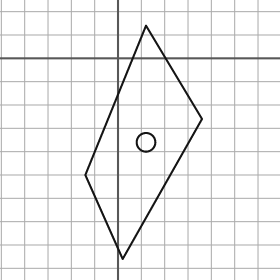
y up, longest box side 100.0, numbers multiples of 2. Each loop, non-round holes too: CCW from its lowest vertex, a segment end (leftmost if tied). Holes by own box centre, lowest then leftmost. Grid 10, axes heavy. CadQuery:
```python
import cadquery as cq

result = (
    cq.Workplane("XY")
    .moveTo(2.0, -86.0)
    .lineTo(36.0, -26.0)
    .lineTo(12.0, 14.0)
    .lineTo(-14.0, -50.0)
    .close()
    .moveTo(12.0, -36.0)
    .circle(4.0)
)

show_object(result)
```